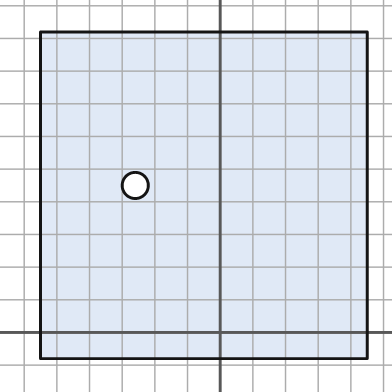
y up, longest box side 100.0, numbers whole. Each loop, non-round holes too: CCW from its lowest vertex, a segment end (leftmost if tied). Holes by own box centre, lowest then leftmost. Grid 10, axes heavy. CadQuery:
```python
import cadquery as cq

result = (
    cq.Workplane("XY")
    .moveTo(-55.0, -8.0)
    .lineTo(45.0, -8.0)
    .lineTo(45.0, 92.0)
    .lineTo(-55.0, 92.0)
    .close()
    .moveTo(-26.0, 45.0)
    .circle(4.0)
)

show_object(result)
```